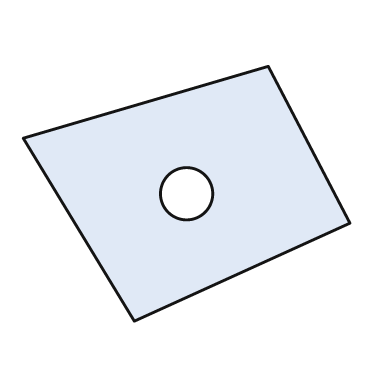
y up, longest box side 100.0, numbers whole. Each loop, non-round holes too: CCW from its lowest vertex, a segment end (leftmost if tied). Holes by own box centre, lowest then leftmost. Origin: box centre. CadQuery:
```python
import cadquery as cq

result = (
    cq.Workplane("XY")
    .moveTo(-16.0, -39.0)
    .lineTo(50.0, -9.0)
    .lineTo(25.0, 39.0)
    .lineTo(-50.0, 17.0)
    .close()
    .moveTo(0.0, 0.0)
    .circle(8.0)
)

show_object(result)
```